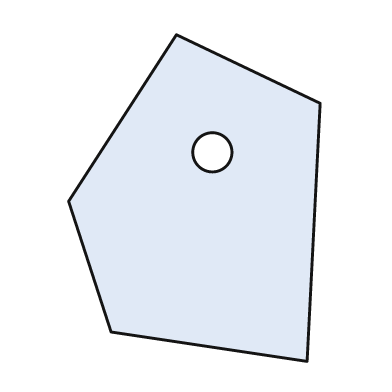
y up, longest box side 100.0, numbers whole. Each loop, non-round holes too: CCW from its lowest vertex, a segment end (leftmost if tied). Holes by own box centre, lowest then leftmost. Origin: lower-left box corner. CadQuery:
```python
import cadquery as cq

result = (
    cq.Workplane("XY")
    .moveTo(73.0, 0.0)
    .lineTo(77.0, 79.0)
    .lineTo(33.0, 100.0)
    .lineTo(0.0, 49.0)
    .lineTo(13.0, 9.0)
    .close()
    .moveTo(44.0, 64.0)
    .circle(6.0)
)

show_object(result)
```